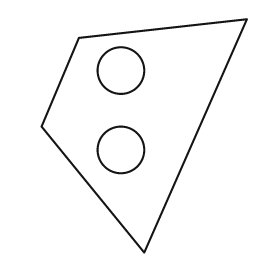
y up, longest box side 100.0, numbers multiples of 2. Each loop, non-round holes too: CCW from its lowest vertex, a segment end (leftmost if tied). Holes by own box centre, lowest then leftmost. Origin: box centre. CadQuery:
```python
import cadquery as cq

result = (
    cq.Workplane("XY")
    .moveTo(0.0, -50.0)
    .lineTo(44.0, 50.0)
    .lineTo(-28.0, 42.0)
    .lineTo(-44.0, 4.0)
    .close()
    .moveTo(-10.0, -6.0)
    .circle(10.0)
    .moveTo(-10.0, 28.0)
    .circle(10.0)
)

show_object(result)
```